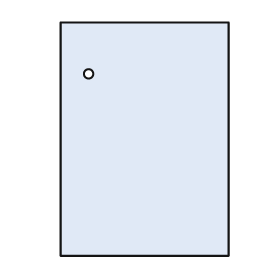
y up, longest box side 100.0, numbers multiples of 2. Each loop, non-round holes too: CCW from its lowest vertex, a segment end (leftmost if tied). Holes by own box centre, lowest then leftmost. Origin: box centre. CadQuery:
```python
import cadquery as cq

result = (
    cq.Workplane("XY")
    .moveTo(-36.0, -50.0)
    .lineTo(36.0, -50.0)
    .lineTo(36.0, 50.0)
    .lineTo(-36.0, 50.0)
    .close()
    .moveTo(-24.0, 28.0)
    .circle(2.0)
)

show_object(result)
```